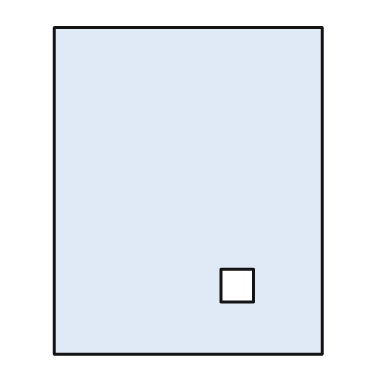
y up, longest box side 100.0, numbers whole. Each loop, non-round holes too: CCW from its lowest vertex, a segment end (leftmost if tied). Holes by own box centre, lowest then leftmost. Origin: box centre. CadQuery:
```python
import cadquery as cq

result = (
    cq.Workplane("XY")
    .moveTo(-41.0, -50.0)
    .lineTo(41.0, -50.0)
    .lineTo(41.0, 50.0)
    .lineTo(-41.0, 50.0)
    .close()
    .moveTo(10.0, -34.0)
    .lineTo(20.0, -34.0)
    .lineTo(20.0, -24.0)
    .lineTo(10.0, -24.0)
    .close()
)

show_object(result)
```